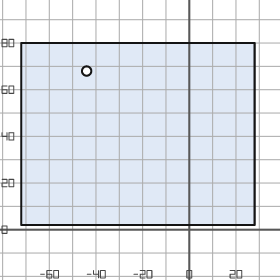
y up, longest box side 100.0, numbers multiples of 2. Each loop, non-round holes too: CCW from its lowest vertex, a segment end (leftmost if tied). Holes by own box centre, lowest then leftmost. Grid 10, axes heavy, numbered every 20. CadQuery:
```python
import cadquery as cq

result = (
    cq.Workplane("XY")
    .moveTo(-72.0, 2.0)
    .lineTo(28.0, 2.0)
    .lineTo(28.0, 80.0)
    .lineTo(-72.0, 80.0)
    .close()
    .moveTo(-44.0, 68.0)
    .circle(2.0)
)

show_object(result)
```